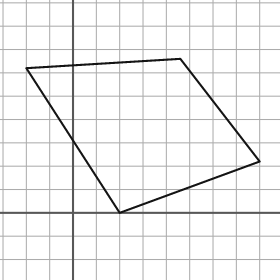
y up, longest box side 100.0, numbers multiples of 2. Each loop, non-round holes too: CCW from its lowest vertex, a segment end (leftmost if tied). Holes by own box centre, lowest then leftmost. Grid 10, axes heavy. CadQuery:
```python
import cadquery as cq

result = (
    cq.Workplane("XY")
    .moveTo(20.0, 0.0)
    .lineTo(80.0, 22.0)
    .lineTo(46.0, 66.0)
    .lineTo(-20.0, 62.0)
    .close()
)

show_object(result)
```